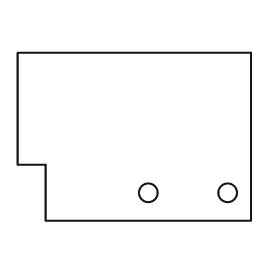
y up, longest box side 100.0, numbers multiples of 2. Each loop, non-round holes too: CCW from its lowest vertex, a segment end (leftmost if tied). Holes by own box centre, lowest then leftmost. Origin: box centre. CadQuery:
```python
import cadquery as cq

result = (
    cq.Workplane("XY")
    .moveTo(-38.0, -36.0)
    .lineTo(50.0, -36.0)
    .lineTo(50.0, 36.0)
    .lineTo(-50.0, 36.0)
    .lineTo(-50.0, -12.0)
    .lineTo(-38.0, -12.0)
    .close()
    .moveTo(6.0, -24.0)
    .circle(4.0)
    .moveTo(40.0, -24.0)
    .circle(4.0)
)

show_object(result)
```